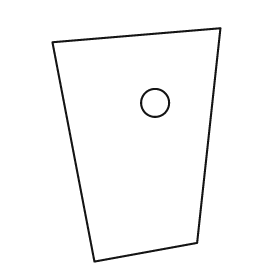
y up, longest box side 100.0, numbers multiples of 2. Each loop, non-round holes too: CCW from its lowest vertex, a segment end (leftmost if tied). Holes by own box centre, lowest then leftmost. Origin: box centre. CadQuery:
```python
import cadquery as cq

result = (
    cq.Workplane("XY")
    .moveTo(-18.0, -50.0)
    .lineTo(26.0, -42.0)
    .lineTo(36.0, 50.0)
    .lineTo(-36.0, 44.0)
    .close()
    .moveTo(8.0, 18.0)
    .circle(6.0)
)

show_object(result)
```